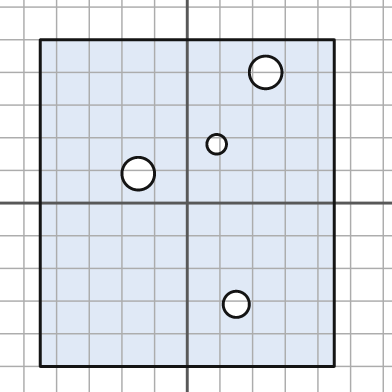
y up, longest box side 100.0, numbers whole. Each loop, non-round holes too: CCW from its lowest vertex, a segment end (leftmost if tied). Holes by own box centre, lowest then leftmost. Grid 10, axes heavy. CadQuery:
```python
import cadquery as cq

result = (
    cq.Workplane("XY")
    .moveTo(-45.0, -50.0)
    .lineTo(45.0, -50.0)
    .lineTo(45.0, 50.0)
    .lineTo(-45.0, 50.0)
    .close()
    .moveTo(15.0, -31.0)
    .circle(4.0)
    .moveTo(-15.0, 9.0)
    .circle(5.0)
    .moveTo(9.0, 18.0)
    .circle(3.0)
    .moveTo(24.0, 40.0)
    .circle(5.0)
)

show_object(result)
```